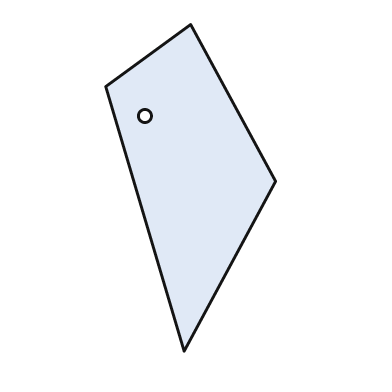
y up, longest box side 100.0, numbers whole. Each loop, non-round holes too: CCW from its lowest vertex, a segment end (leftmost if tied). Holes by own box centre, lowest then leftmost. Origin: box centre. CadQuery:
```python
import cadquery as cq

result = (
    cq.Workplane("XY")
    .moveTo(-2.0, -50.0)
    .lineTo(26.0, 2.0)
    .lineTo(0.0, 50.0)
    .lineTo(-26.0, 31.0)
    .close()
    .moveTo(-14.0, 22.0)
    .circle(2.0)
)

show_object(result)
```